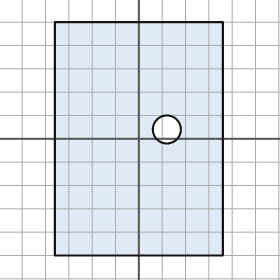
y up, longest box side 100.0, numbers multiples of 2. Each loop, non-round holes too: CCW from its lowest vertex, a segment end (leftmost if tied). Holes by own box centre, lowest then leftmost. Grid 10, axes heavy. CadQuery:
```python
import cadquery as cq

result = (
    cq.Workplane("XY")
    .moveTo(-36.0, -50.0)
    .lineTo(36.0, -50.0)
    .lineTo(36.0, 50.0)
    .lineTo(-36.0, 50.0)
    .close()
    .moveTo(12.0, 4.0)
    .circle(6.0)
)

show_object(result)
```